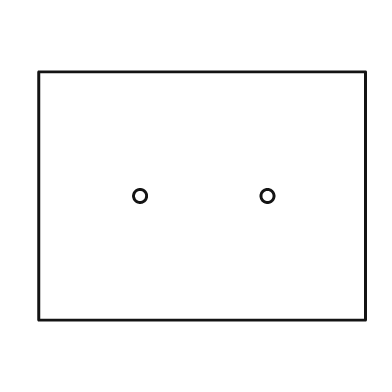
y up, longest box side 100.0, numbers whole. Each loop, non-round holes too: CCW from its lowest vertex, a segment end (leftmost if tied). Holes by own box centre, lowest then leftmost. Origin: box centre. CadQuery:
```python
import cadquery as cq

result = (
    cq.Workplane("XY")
    .moveTo(-50.0, -38.0)
    .lineTo(50.0, -38.0)
    .lineTo(50.0, 38.0)
    .lineTo(-50.0, 38.0)
    .close()
    .moveTo(-19.0, 0.0)
    .circle(2.0)
    .moveTo(20.0, 0.0)
    .circle(2.0)
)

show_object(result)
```